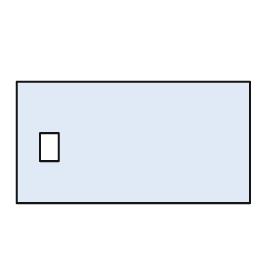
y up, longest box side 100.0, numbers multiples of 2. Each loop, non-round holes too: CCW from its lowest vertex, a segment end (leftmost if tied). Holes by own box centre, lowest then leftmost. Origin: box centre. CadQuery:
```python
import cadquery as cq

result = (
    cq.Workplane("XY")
    .moveTo(-50.0, -26.0)
    .lineTo(50.0, -26.0)
    .lineTo(50.0, 26.0)
    .lineTo(-50.0, 26.0)
    .close()
    .moveTo(-40.0, -8.0)
    .lineTo(-32.0, -8.0)
    .lineTo(-32.0, 4.0)
    .lineTo(-40.0, 4.0)
    .close()
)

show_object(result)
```